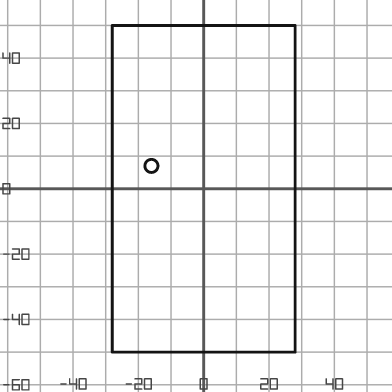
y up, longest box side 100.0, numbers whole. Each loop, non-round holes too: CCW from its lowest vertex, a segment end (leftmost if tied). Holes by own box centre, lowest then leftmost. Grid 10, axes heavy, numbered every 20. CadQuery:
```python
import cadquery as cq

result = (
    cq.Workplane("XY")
    .moveTo(-28.0, -50.0)
    .lineTo(28.0, -50.0)
    .lineTo(28.0, 50.0)
    .lineTo(-28.0, 50.0)
    .close()
    .moveTo(-16.0, 7.0)
    .circle(2.0)
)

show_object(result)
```